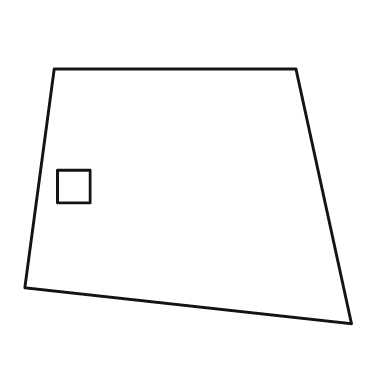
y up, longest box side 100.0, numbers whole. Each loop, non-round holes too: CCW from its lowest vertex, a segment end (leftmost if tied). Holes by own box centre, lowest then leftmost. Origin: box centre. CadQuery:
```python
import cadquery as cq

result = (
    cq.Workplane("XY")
    .moveTo(50.0, -39.0)
    .lineTo(33.0, 39.0)
    .lineTo(-41.0, 39.0)
    .lineTo(-50.0, -28.0)
    .close()
    .moveTo(-40.0, -2.0)
    .lineTo(-30.0, -2.0)
    .lineTo(-30.0, 8.0)
    .lineTo(-40.0, 8.0)
    .close()
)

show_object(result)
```